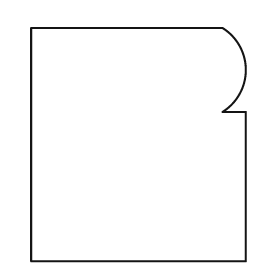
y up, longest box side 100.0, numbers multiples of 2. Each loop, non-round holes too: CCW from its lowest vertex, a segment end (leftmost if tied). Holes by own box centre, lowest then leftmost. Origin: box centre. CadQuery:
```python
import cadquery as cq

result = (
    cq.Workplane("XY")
    .moveTo(-46.0, -50.0)
    .lineTo(46.0, -50.0)
    .lineTo(46.0, 14.0)
    .lineTo(36.0, 14.0)
    .threePointArc((46.0, 32.0), (36.0, 50.0))
    .lineTo(-46.0, 50.0)
    .close()
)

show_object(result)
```